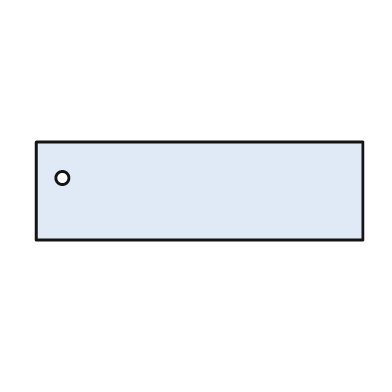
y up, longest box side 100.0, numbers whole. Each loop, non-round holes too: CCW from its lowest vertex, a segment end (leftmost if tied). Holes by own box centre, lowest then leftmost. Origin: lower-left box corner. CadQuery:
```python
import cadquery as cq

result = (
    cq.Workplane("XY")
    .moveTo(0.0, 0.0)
    .lineTo(100.0, 0.0)
    .lineTo(100.0, 30.0)
    .lineTo(0.0, 30.0)
    .close()
    .moveTo(8.0, 19.0)
    .circle(2.0)
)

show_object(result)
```